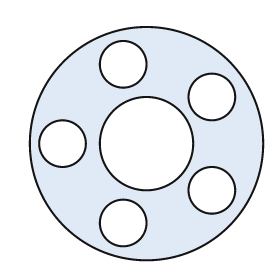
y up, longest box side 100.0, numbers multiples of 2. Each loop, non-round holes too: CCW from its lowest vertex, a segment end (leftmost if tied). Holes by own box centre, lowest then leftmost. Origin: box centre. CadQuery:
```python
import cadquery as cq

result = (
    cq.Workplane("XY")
    .moveTo(0.0, 0.0)
    .circle(50.0)
    .moveTo(-10.0, -34.0)
    .circle(10.0)
    .moveTo(28.0, -20.0)
    .circle(10.0)
    .moveTo(-36.0, 0.0)
    .circle(10.0)
    .moveTo(0.0, 0.0)
    .circle(20.0)
    .moveTo(28.0, 20.0)
    .circle(10.0)
    .moveTo(-10.0, 34.0)
    .circle(10.0)
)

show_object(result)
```